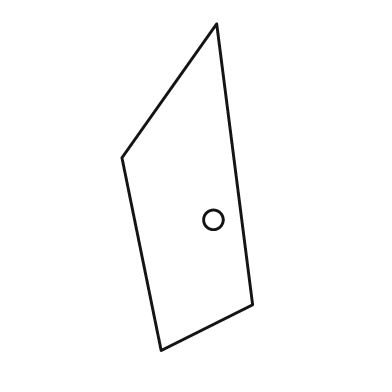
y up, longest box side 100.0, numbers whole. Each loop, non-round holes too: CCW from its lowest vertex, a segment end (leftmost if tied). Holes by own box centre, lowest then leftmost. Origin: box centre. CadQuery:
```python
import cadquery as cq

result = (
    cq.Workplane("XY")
    .moveTo(-8.0, -50.0)
    .lineTo(20.0, -36.0)
    .lineTo(9.0, 50.0)
    .lineTo(-20.0, 9.0)
    .close()
    .moveTo(8.0, -10.0)
    .circle(3.0)
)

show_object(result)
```